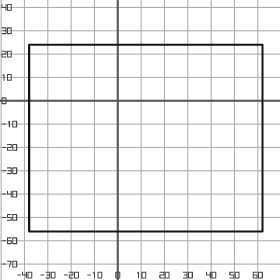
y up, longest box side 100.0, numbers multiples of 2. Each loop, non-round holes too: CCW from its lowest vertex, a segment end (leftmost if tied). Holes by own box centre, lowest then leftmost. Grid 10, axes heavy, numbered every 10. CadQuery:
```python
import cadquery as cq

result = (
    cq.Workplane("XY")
    .moveTo(-38.0, -56.0)
    .lineTo(62.0, -56.0)
    .lineTo(62.0, 24.0)
    .lineTo(-38.0, 24.0)
    .close()
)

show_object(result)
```